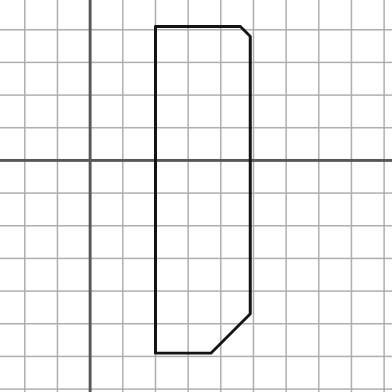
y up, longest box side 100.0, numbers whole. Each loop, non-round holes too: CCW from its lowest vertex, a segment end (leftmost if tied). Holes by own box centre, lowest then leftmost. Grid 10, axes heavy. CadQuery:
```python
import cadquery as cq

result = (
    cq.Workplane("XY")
    .moveTo(20.0, -59.0)
    .lineTo(37.0, -59.0)
    .lineTo(49.0, -47.0)
    .lineTo(49.0, 38.0)
    .lineTo(46.0, 41.0)
    .lineTo(20.0, 41.0)
    .close()
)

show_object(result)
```